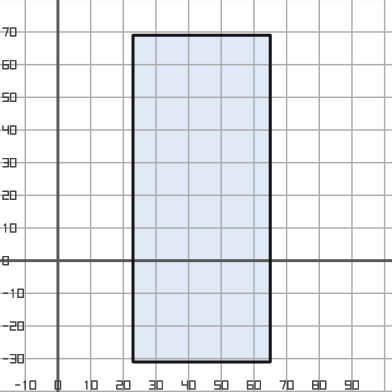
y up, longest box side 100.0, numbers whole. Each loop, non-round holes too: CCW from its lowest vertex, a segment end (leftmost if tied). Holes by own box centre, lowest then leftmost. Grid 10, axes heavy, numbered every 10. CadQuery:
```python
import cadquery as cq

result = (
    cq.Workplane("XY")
    .moveTo(23.0, -31.0)
    .lineTo(65.0, -31.0)
    .lineTo(65.0, 69.0)
    .lineTo(23.0, 69.0)
    .close()
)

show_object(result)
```